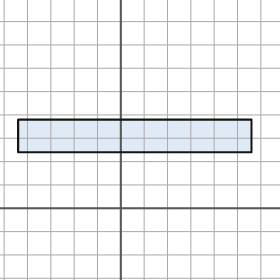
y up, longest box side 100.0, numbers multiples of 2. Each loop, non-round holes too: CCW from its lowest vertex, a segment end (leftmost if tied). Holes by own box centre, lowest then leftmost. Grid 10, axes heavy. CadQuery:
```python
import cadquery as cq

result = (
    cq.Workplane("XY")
    .moveTo(-44.0, 24.0)
    .lineTo(56.0, 24.0)
    .lineTo(56.0, 38.0)
    .lineTo(-44.0, 38.0)
    .close()
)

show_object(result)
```